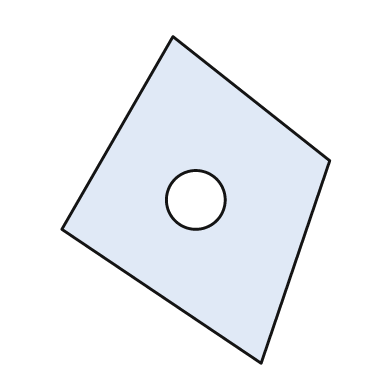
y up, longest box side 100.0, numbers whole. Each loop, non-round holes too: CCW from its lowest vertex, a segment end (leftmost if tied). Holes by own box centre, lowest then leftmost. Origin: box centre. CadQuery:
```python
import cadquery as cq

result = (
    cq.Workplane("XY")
    .moveTo(20.0, -50.0)
    .lineTo(41.0, 12.0)
    .lineTo(-7.0, 50.0)
    .lineTo(-41.0, -9.0)
    .close()
    .moveTo(0.0, 0.0)
    .circle(9.0)
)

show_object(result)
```